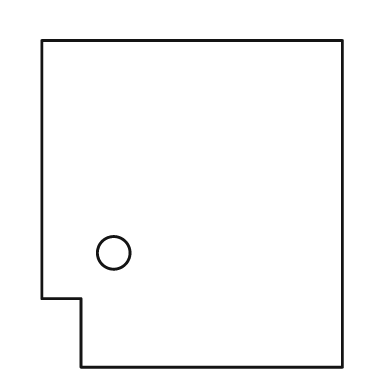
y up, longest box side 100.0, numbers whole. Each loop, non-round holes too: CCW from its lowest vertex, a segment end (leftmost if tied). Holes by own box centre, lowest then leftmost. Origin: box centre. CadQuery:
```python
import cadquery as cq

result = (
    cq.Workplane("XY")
    .moveTo(-34.0, -50.0)
    .lineTo(46.0, -50.0)
    .lineTo(46.0, 50.0)
    .lineTo(-46.0, 50.0)
    .lineTo(-46.0, -29.0)
    .lineTo(-34.0, -29.0)
    .close()
    .moveTo(-24.0, -15.0)
    .circle(5.0)
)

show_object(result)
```